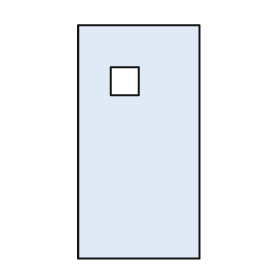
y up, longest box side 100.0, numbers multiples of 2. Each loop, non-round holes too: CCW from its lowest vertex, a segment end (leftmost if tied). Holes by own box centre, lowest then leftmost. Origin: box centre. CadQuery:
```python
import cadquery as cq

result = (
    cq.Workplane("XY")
    .moveTo(-26.0, -50.0)
    .lineTo(26.0, -50.0)
    .lineTo(26.0, 50.0)
    .lineTo(-26.0, 50.0)
    .close()
    .moveTo(-12.0, 20.0)
    .lineTo(0.0, 20.0)
    .lineTo(0.0, 32.0)
    .lineTo(-12.0, 32.0)
    .close()
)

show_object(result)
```